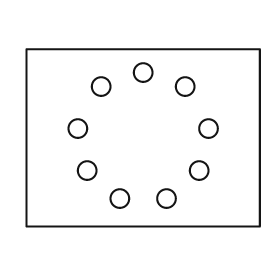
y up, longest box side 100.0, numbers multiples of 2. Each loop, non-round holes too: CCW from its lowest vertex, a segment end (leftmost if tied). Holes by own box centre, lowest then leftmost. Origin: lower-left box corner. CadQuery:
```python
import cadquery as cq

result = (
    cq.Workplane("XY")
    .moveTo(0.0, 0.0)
    .lineTo(100.0, 0.0)
    .lineTo(100.0, 76.0)
    .lineTo(0.0, 76.0)
    .close()
    .moveTo(40.0, 12.0)
    .circle(4.0)
    .moveTo(60.0, 12.0)
    .circle(4.0)
    .moveTo(26.0, 24.0)
    .circle(4.0)
    .moveTo(74.0, 24.0)
    .circle(4.0)
    .moveTo(22.0, 42.0)
    .circle(4.0)
    .moveTo(78.0, 42.0)
    .circle(4.0)
    .moveTo(32.0, 60.0)
    .circle(4.0)
    .moveTo(68.0, 60.0)
    .circle(4.0)
    .moveTo(50.0, 66.0)
    .circle(4.0)
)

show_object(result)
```